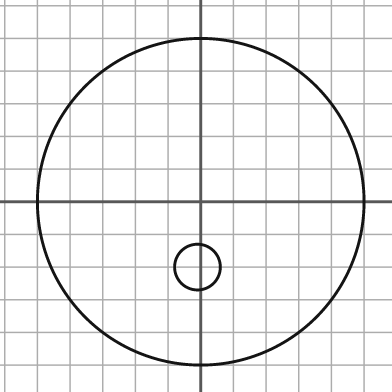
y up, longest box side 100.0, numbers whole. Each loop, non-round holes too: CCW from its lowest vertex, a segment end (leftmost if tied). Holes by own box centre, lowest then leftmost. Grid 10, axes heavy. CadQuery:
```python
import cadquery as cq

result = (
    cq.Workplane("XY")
    .moveTo(0.0, 0.0)
    .circle(50.0)
    .moveTo(-1.0, -20.0)
    .circle(7.0)
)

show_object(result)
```